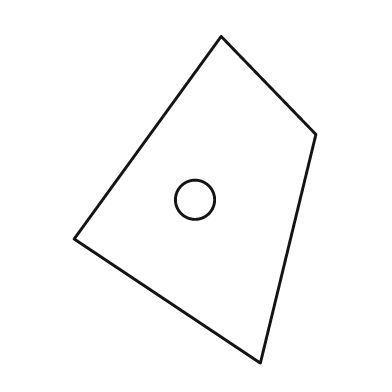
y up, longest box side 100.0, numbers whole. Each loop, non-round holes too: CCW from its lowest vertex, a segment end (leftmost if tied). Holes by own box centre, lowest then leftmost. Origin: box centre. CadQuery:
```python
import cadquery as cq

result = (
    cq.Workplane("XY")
    .moveTo(20.0, -50.0)
    .lineTo(37.0, 20.0)
    .lineTo(8.0, 50.0)
    .lineTo(-37.0, -12.0)
    .close()
    .moveTo(0.0, 0.0)
    .circle(6.0)
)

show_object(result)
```